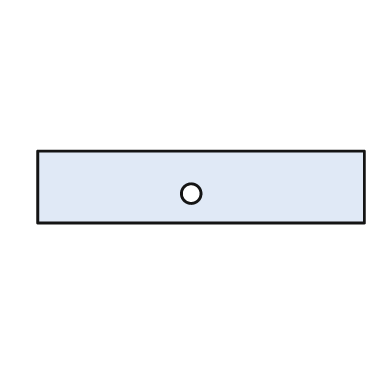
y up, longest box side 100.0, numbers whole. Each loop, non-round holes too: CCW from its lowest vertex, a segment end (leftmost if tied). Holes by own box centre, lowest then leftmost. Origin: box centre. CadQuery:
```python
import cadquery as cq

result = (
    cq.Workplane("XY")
    .moveTo(-50.0, -11.0)
    .lineTo(50.0, -11.0)
    .lineTo(50.0, 11.0)
    .lineTo(-50.0, 11.0)
    .close()
    .moveTo(-3.0, -2.0)
    .circle(3.0)
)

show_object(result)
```